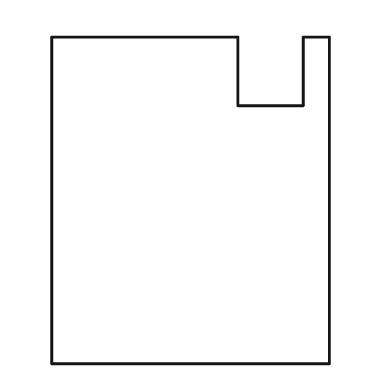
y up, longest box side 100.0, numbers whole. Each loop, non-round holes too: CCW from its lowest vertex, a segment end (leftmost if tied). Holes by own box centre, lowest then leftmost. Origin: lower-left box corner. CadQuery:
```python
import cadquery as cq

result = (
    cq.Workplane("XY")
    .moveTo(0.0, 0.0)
    .lineTo(85.0, 0.0)
    .lineTo(85.0, 100.0)
    .lineTo(77.0, 100.0)
    .lineTo(77.0, 79.0)
    .lineTo(57.0, 79.0)
    .lineTo(57.0, 100.0)
    .lineTo(0.0, 100.0)
    .close()
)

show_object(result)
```